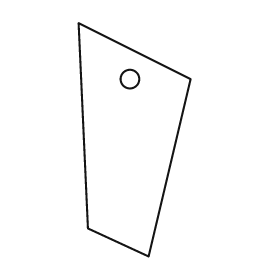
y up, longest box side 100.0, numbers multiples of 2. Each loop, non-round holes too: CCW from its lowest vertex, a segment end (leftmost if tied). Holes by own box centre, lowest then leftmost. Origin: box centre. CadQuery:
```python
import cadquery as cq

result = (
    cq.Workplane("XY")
    .moveTo(6.0, -50.0)
    .lineTo(24.0, 26.0)
    .lineTo(-24.0, 50.0)
    .lineTo(-20.0, -38.0)
    .close()
    .moveTo(-2.0, 26.0)
    .circle(4.0)
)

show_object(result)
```